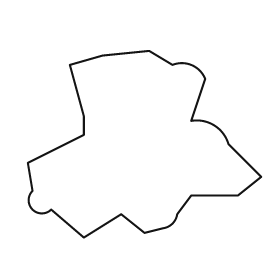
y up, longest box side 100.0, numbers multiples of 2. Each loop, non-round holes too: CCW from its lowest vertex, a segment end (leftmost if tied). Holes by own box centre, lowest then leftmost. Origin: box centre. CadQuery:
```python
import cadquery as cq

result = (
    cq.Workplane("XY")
    .moveTo(-26.0, -40.0)
    .lineTo(-10.0, -30.0)
    .lineTo(0.0, -38.0)
    .lineTo(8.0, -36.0)
    .threePointArc((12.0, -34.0), (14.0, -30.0))
    .lineTo(20.0, -22.0)
    .lineTo(40.0, -22.0)
    .lineTo(50.0, -14.0)
    .lineTo(36.0, 0.0)
    .threePointArc((30.0, 8.0), (20.0, 10.0))
    .lineTo(26.0, 28.0)
    .threePointArc((20.0, 34.0), (12.0, 34.0))
    .lineTo(2.0, 40.0)
    .lineTo(-18.0, 38.0)
    .lineTo(-32.0, 34.0)
    .lineTo(-26.0, 12.0)
    .lineTo(-26.0, 4.0)
    .lineTo(-50.0, -8.0)
    .lineTo(-48.0, -20.0)
    .threePointArc((-48.0, -28.0), (-40.0, -28.0))
    .close()
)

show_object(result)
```